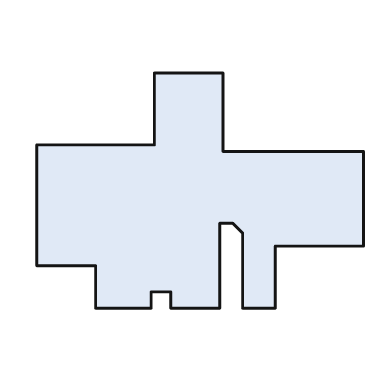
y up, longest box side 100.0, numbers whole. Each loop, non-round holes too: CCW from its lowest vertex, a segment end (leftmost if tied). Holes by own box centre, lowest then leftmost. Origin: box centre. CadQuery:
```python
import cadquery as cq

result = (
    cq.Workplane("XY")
    .moveTo(-32.0, -36.0)
    .lineTo(-15.0, -36.0)
    .lineTo(-15.0, -31.0)
    .lineTo(-9.0, -31.0)
    .lineTo(-9.0, -36.0)
    .lineTo(6.0, -36.0)
    .lineTo(6.0, -10.0)
    .lineTo(10.0, -10.0)
    .lineTo(13.0, -13.0)
    .lineTo(13.0, -36.0)
    .lineTo(23.0, -36.0)
    .lineTo(23.0, -17.0)
    .lineTo(50.0, -17.0)
    .lineTo(50.0, 12.0)
    .lineTo(7.0, 12.0)
    .lineTo(7.0, 36.0)
    .lineTo(-14.0, 36.0)
    .lineTo(-14.0, 14.0)
    .lineTo(-50.0, 14.0)
    .lineTo(-50.0, -23.0)
    .lineTo(-32.0, -23.0)
    .close()
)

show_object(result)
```